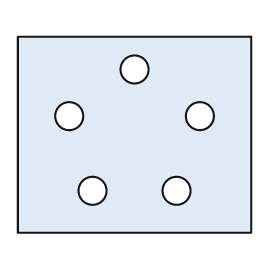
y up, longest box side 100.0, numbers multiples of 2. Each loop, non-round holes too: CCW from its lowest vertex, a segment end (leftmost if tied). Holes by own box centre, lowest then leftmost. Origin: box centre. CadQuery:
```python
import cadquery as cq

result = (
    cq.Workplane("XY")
    .moveTo(-50.0, -42.0)
    .lineTo(50.0, -42.0)
    .lineTo(50.0, 42.0)
    .lineTo(-50.0, 42.0)
    .close()
    .moveTo(-18.0, -24.0)
    .circle(6.0)
    .moveTo(18.0, -24.0)
    .circle(6.0)
    .moveTo(-28.0, 8.0)
    .circle(6.0)
    .moveTo(28.0, 8.0)
    .circle(6.0)
    .moveTo(0.0, 28.0)
    .circle(6.0)
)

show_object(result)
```